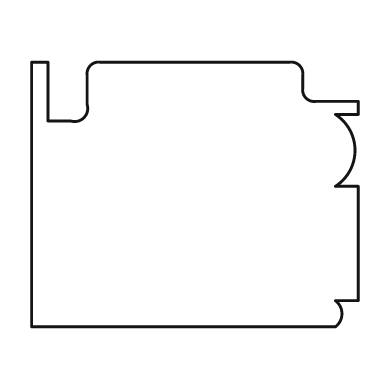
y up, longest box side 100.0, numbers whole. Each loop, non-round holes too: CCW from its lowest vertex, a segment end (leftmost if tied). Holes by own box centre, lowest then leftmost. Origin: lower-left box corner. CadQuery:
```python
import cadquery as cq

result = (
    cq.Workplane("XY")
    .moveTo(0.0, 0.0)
    .lineTo(93.0, 0.0)
    .threePointArc((95.0, 4.0), (93.0, 8.0))
    .lineTo(100.0, 8.0)
    .lineTo(100.0, 43.0)
    .lineTo(93.0, 43.0)
    .threePointArc((99.0, 54.0), (93.0, 65.0))
    .lineTo(100.0, 65.0)
    .lineTo(100.0, 69.0)
    .lineTo(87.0, 69.0)
    .threePointArc((84.0, 70.0), (83.0, 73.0))
    .lineTo(83.0, 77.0)
    .threePointArc((82.0, 80.0), (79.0, 81.0))
    .lineTo(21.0, 81.0)
    .threePointArc((18.0, 80.0), (17.0, 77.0))
    .lineTo(17.0, 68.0)
    .threePointArc((16.0, 64.0), (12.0, 63.0))
    .lineTo(5.0, 63.0)
    .lineTo(5.0, 81.0)
    .lineTo(0.0, 81.0)
    .close()
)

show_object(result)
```